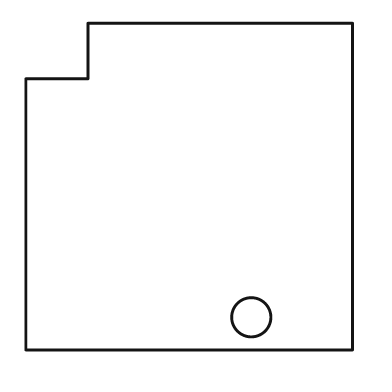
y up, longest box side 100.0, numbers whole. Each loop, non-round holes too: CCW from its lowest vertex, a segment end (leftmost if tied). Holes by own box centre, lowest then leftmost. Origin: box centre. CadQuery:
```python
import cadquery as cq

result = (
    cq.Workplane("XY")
    .moveTo(-50.0, -50.0)
    .lineTo(50.0, -50.0)
    .lineTo(50.0, 50.0)
    .lineTo(-31.0, 50.0)
    .lineTo(-31.0, 33.0)
    .lineTo(-50.0, 33.0)
    .close()
    .moveTo(19.0, -40.0)
    .circle(6.0)
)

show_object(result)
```